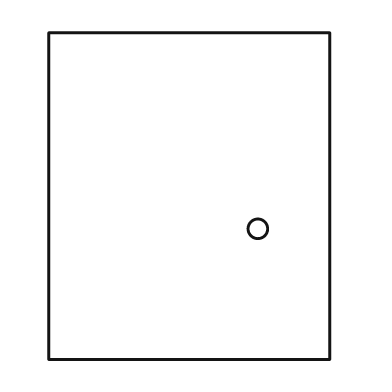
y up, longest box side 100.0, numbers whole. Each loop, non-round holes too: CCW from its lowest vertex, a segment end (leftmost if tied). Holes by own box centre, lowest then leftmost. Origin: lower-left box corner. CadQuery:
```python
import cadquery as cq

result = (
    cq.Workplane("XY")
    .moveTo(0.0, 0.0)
    .lineTo(86.0, 0.0)
    .lineTo(86.0, 100.0)
    .lineTo(0.0, 100.0)
    .close()
    .moveTo(64.0, 40.0)
    .circle(3.0)
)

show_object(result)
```